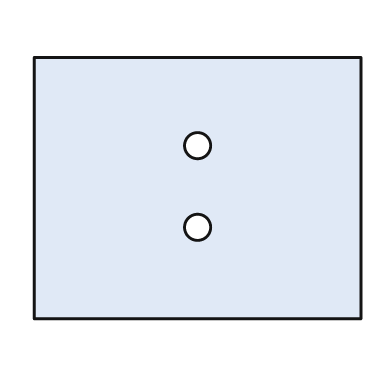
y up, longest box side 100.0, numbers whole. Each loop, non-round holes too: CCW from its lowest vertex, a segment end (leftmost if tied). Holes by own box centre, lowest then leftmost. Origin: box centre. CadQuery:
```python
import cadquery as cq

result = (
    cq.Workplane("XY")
    .moveTo(-50.0, -40.0)
    .lineTo(50.0, -40.0)
    .lineTo(50.0, 40.0)
    .lineTo(-50.0, 40.0)
    .close()
    .moveTo(0.0, -12.0)
    .circle(4.0)
    .moveTo(0.0, 13.0)
    .circle(4.0)
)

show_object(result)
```